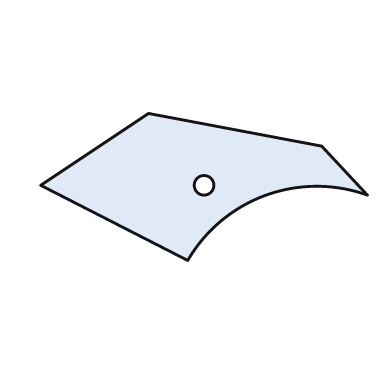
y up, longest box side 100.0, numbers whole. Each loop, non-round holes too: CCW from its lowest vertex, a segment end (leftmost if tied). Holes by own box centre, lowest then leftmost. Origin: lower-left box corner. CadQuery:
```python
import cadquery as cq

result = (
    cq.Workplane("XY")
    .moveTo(45.0, 0.0)
    .threePointArc((69.0, 20.0), (100.0, 20.0))
    .lineTo(86.0, 35.0)
    .lineTo(33.0, 45.0)
    .lineTo(0.0, 23.0)
    .close()
    .moveTo(50.0, 23.0)
    .circle(3.0)
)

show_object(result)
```